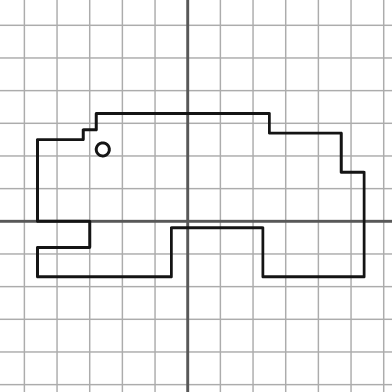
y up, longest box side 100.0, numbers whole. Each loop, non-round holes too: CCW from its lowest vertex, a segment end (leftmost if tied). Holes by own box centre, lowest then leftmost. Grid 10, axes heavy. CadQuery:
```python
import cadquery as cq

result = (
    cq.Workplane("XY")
    .moveTo(-46.0, -17.0)
    .lineTo(-5.0, -17.0)
    .lineTo(-5.0, -2.0)
    .lineTo(23.0, -2.0)
    .lineTo(23.0, -17.0)
    .lineTo(54.0, -17.0)
    .lineTo(54.0, 15.0)
    .lineTo(47.0, 15.0)
    .lineTo(47.0, 27.0)
    .lineTo(25.0, 27.0)
    .lineTo(25.0, 33.0)
    .lineTo(-28.0, 33.0)
    .lineTo(-28.0, 28.0)
    .lineTo(-32.0, 28.0)
    .lineTo(-32.0, 25.0)
    .lineTo(-46.0, 25.0)
    .lineTo(-46.0, 0.0)
    .lineTo(-30.0, 0.0)
    .lineTo(-30.0, -8.0)
    .lineTo(-46.0, -8.0)
    .close()
    .moveTo(-26.0, 22.0)
    .circle(2.0)
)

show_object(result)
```